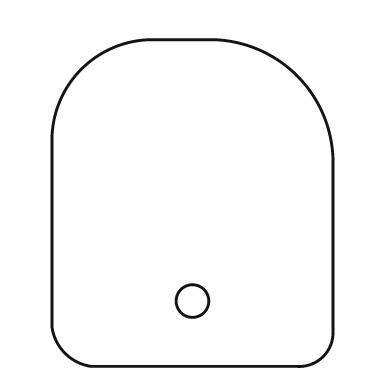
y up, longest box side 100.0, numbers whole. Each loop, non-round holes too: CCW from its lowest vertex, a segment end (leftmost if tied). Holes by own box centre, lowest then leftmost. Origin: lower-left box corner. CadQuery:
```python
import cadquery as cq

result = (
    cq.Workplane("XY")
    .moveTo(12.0, 0.0)
    .lineTo(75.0, 0.0)
    .threePointArc((83.0, 3.0), (86.0, 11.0))
    .lineTo(86.0, 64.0)
    .threePointArc((75.0, 89.0), (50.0, 100.0))
    .lineTo(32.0, 100.0)
    .threePointArc((9.0, 91.0), (0.0, 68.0))
    .lineTo(0.0, 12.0)
    .threePointArc((4.0, 4.0), (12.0, 0.0))
    .close()
    .moveTo(43.0, 20.0)
    .circle(5.0)
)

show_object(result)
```